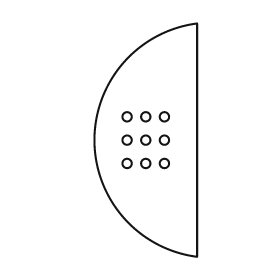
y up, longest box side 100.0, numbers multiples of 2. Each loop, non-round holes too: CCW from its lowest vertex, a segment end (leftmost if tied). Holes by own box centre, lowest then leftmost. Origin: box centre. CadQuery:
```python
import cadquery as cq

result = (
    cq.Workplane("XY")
    .moveTo(22.0, -50.0)
    .lineTo(22.0, 50.0)
    .threePointArc((-22.0, 0.0), (22.0, -50.0))
    .close()
    .moveTo(-8.0, -10.0)
    .circle(2.0)
    .moveTo(0.0, -10.0)
    .circle(2.0)
    .moveTo(8.0, -10.0)
    .circle(2.0)
    .moveTo(-8.0, 0.0)
    .circle(2.0)
    .moveTo(0.0, 0.0)
    .circle(2.0)
    .moveTo(8.0, 0.0)
    .circle(2.0)
    .moveTo(-8.0, 10.0)
    .circle(2.0)
    .moveTo(0.0, 10.0)
    .circle(2.0)
    .moveTo(8.0, 10.0)
    .circle(2.0)
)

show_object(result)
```